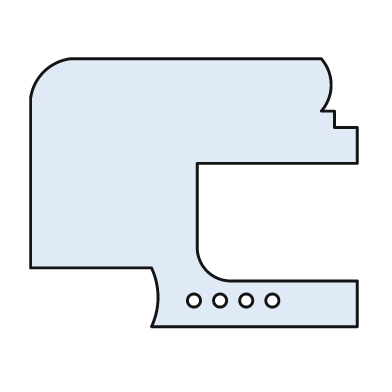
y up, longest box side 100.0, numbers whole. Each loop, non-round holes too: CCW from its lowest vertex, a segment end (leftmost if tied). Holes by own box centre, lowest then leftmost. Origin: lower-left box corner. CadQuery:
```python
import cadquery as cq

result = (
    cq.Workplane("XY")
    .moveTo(37.0, 0.0)
    .lineTo(100.0, 0.0)
    .lineTo(100.0, 14.0)
    .lineTo(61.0, 14.0)
    .threePointArc((54.0, 17.0), (51.0, 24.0))
    .lineTo(51.0, 50.0)
    .lineTo(100.0, 50.0)
    .lineTo(100.0, 61.0)
    .lineTo(93.0, 61.0)
    .lineTo(93.0, 66.0)
    .lineTo(89.0, 66.0)
    .threePointArc((92.0, 74.0), (89.0, 82.0))
    .lineTo(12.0, 82.0)
    .threePointArc((4.0, 78.0), (0.0, 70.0))
    .lineTo(0.0, 18.0)
    .lineTo(37.0, 18.0)
    .threePointArc((39.0, 9.0), (37.0, 0.0))
    .close()
    .moveTo(50.0, 8.0)
    .circle(2.0)
    .moveTo(58.0, 8.0)
    .circle(2.0)
    .moveTo(66.0, 8.0)
    .circle(2.0)
    .moveTo(74.0, 8.0)
    .circle(2.0)
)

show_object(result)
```